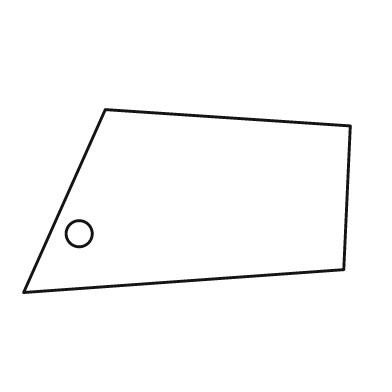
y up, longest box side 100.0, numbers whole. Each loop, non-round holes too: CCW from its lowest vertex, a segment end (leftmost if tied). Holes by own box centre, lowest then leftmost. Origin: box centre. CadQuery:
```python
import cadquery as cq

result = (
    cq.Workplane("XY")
    .moveTo(-50.0, -28.0)
    .lineTo(48.0, -21.0)
    .lineTo(50.0, 23.0)
    .lineTo(-25.0, 28.0)
    .close()
    .moveTo(-33.0, -10.0)
    .circle(4.0)
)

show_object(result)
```